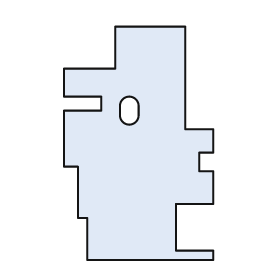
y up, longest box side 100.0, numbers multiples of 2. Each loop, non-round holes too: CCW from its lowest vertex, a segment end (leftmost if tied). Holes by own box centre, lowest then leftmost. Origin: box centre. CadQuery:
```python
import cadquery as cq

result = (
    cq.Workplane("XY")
    .moveTo(-22.0, -50.0)
    .lineTo(32.0, -50.0)
    .lineTo(32.0, -46.0)
    .lineTo(16.0, -46.0)
    .lineTo(16.0, -26.0)
    .lineTo(32.0, -26.0)
    .lineTo(32.0, -12.0)
    .lineTo(26.0, -12.0)
    .lineTo(26.0, -4.0)
    .lineTo(32.0, -4.0)
    .lineTo(32.0, 6.0)
    .lineTo(20.0, 6.0)
    .lineTo(20.0, 50.0)
    .lineTo(-10.0, 50.0)
    .lineTo(-10.0, 32.0)
    .lineTo(-32.0, 32.0)
    .lineTo(-32.0, 20.0)
    .lineTo(-16.0, 20.0)
    .lineTo(-16.0, 14.0)
    .lineTo(-32.0, 14.0)
    .lineTo(-32.0, -10.0)
    .lineTo(-26.0, -10.0)
    .lineTo(-26.0, -32.0)
    .lineTo(-22.0, -32.0)
    .close()
    .moveTo(-8.0, 12.0)
    .threePointArc((-4.0, 8.0), (0.0, 12.0))
    .lineTo(0.0, 16.0)
    .threePointArc((-4.0, 20.0), (-8.0, 16.0))
    .close()
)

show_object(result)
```